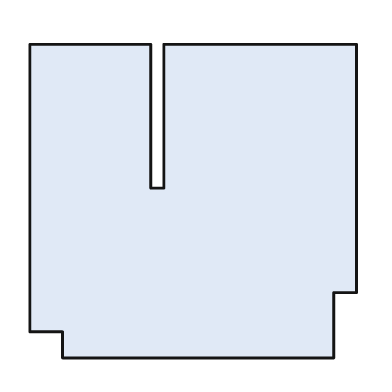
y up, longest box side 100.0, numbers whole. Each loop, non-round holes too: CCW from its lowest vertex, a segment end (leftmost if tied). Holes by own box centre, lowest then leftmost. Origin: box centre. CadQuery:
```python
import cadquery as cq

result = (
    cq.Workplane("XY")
    .moveTo(-40.0, -48.0)
    .lineTo(43.0, -48.0)
    .lineTo(43.0, -28.0)
    .lineTo(50.0, -28.0)
    .lineTo(50.0, 48.0)
    .lineTo(-9.0, 48.0)
    .lineTo(-9.0, 4.0)
    .lineTo(-13.0, 4.0)
    .lineTo(-13.0, 48.0)
    .lineTo(-50.0, 48.0)
    .lineTo(-50.0, -40.0)
    .lineTo(-40.0, -40.0)
    .close()
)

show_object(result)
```